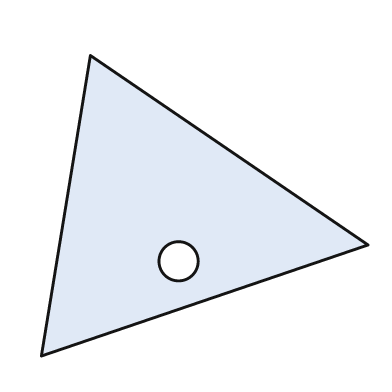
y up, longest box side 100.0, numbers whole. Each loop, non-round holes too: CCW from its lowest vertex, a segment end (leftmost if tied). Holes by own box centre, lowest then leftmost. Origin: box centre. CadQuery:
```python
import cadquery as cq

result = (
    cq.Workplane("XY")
    .moveTo(-50.0, -46.0)
    .lineTo(50.0, -12.0)
    .lineTo(-35.0, 46.0)
    .close()
    .moveTo(-8.0, -17.0)
    .circle(6.0)
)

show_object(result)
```